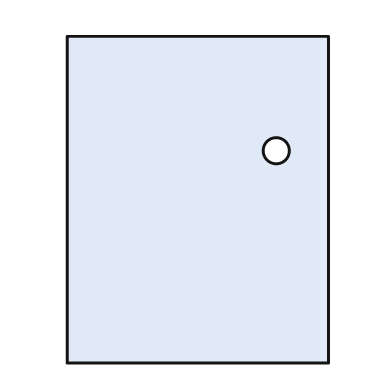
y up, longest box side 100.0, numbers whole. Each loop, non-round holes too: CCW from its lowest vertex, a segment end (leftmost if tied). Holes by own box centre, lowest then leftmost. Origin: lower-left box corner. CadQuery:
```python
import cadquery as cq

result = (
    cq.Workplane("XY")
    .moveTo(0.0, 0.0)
    .lineTo(80.0, 0.0)
    .lineTo(80.0, 100.0)
    .lineTo(0.0, 100.0)
    .close()
    .moveTo(64.0, 65.0)
    .circle(4.0)
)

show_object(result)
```